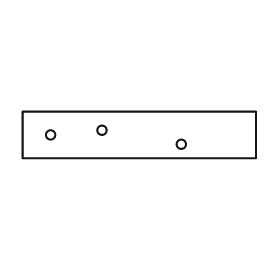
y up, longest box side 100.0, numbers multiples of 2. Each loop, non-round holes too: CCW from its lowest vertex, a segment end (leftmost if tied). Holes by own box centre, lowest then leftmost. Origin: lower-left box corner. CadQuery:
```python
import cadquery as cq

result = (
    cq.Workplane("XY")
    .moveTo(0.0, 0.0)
    .lineTo(100.0, 0.0)
    .lineTo(100.0, 20.0)
    .lineTo(0.0, 20.0)
    .close()
    .moveTo(68.0, 6.0)
    .circle(2.0)
    .moveTo(12.0, 10.0)
    .circle(2.0)
    .moveTo(34.0, 12.0)
    .circle(2.0)
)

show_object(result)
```